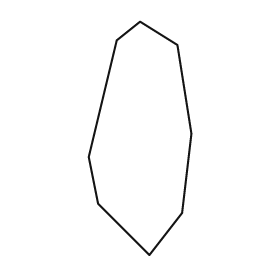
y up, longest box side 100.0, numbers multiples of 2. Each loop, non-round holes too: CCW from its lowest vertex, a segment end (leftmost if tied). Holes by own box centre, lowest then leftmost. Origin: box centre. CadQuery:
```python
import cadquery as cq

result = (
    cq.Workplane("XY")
    .moveTo(4.0, -50.0)
    .lineTo(18.0, -32.0)
    .lineTo(22.0, 2.0)
    .lineTo(16.0, 40.0)
    .lineTo(0.0, 50.0)
    .lineTo(-10.0, 42.0)
    .lineTo(-22.0, -8.0)
    .lineTo(-18.0, -28.0)
    .close()
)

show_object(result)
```